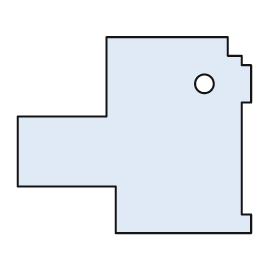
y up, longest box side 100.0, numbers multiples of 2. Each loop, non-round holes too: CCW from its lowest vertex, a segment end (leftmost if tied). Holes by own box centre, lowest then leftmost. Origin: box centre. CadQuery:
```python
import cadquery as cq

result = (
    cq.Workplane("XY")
    .moveTo(-8.0, -42.0)
    .lineTo(50.0, -42.0)
    .lineTo(50.0, -34.0)
    .lineTo(46.0, -34.0)
    .lineTo(46.0, 14.0)
    .lineTo(50.0, 14.0)
    .lineTo(50.0, 30.0)
    .lineTo(46.0, 30.0)
    .lineTo(46.0, 34.0)
    .lineTo(40.0, 34.0)
    .lineTo(40.0, 42.0)
    .lineTo(-12.0, 42.0)
    .lineTo(-12.0, 8.0)
    .lineTo(-50.0, 8.0)
    .lineTo(-50.0, -22.0)
    .lineTo(-8.0, -22.0)
    .close()
    .moveTo(30.0, 22.0)
    .circle(4.0)
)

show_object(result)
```